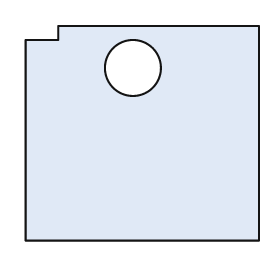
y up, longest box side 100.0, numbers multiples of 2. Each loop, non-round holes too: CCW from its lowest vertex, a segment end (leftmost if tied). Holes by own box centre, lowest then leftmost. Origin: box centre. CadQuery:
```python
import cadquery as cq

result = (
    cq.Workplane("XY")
    .moveTo(-50.0, -46.0)
    .lineTo(50.0, -46.0)
    .lineTo(50.0, 46.0)
    .lineTo(-36.0, 46.0)
    .lineTo(-36.0, 40.0)
    .lineTo(-50.0, 40.0)
    .close()
    .moveTo(-4.0, 28.0)
    .circle(12.0)
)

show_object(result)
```